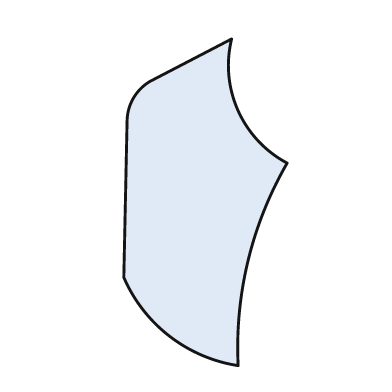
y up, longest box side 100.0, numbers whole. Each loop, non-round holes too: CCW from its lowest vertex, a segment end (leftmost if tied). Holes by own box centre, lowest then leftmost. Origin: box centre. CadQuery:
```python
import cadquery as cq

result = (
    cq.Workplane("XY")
    .moveTo(10.0, -50.0)
    .threePointArc((13.0, -18.0), (25.0, 12.0))
    .threePointArc((10.0, 28.0), (8.0, 50.0))
    .lineTo(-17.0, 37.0)
    .threePointArc((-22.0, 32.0), (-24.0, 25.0))
    .lineTo(-25.0, -23.0)
    .threePointArc((-11.0, -41.0), (10.0, -50.0))
    .close()
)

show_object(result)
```